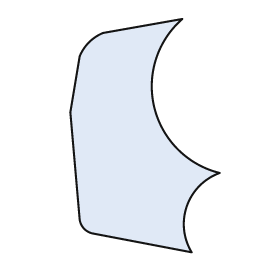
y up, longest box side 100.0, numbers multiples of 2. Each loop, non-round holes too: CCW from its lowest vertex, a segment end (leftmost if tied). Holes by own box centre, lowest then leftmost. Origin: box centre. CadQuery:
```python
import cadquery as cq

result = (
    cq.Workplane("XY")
    .moveTo(20.0, -50.0)
    .threePointArc((18.0, -30.0), (32.0, -16.0))
    .threePointArc((4.0, 12.0), (16.0, 50.0))
    .lineTo(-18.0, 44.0)
    .threePointArc((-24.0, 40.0), (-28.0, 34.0))
    .lineTo(-32.0, 10.0)
    .lineTo(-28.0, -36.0)
    .threePointArc((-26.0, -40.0), (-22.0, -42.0))
    .close()
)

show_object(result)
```